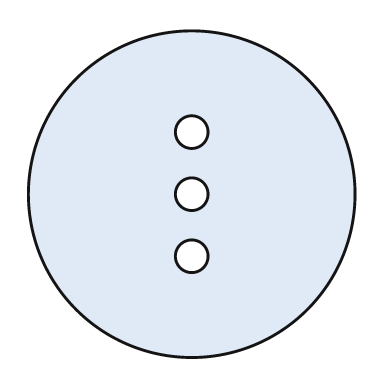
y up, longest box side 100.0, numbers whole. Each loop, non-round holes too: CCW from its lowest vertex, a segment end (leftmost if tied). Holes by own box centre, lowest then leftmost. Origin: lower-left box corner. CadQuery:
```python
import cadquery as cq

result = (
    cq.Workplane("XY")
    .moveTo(50.0, 50.0)
    .circle(50.0)
    .moveTo(50.0, 31.0)
    .circle(5.0)
    .moveTo(50.0, 50.0)
    .circle(5.0)
    .moveTo(50.0, 69.0)
    .circle(5.0)
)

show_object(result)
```